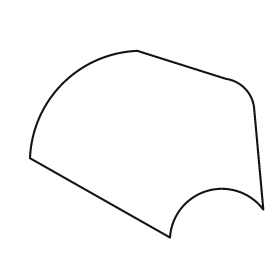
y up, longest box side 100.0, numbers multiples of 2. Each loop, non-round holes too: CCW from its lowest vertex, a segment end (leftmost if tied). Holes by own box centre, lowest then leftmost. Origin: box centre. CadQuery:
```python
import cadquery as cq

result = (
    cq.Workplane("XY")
    .moveTo(10.0, -40.0)
    .threePointArc((26.0, -20.0), (50.0, -28.0))
    .lineTo(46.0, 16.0)
    .threePointArc((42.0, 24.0), (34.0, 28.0))
    .lineTo(-4.0, 40.0)
    .threePointArc((-36.0, 26.0), (-50.0, -6.0))
    .close()
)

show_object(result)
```